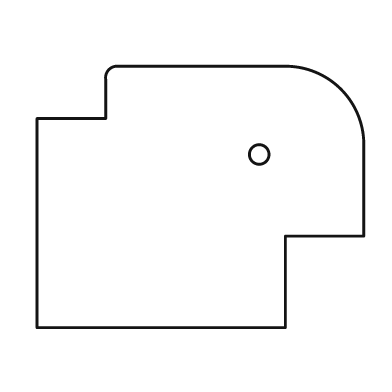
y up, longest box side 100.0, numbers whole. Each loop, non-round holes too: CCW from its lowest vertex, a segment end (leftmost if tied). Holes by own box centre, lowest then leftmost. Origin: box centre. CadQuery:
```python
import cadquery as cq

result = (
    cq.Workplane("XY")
    .moveTo(-50.0, -40.0)
    .lineTo(26.0, -40.0)
    .lineTo(26.0, -12.0)
    .lineTo(50.0, -12.0)
    .lineTo(50.0, 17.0)
    .threePointArc((43.0, 33.0), (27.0, 40.0))
    .lineTo(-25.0, 40.0)
    .threePointArc((-28.0, 39.0), (-29.0, 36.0))
    .lineTo(-29.0, 24.0)
    .lineTo(-50.0, 24.0)
    .close()
    .moveTo(18.0, 13.0)
    .circle(3.0)
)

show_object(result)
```